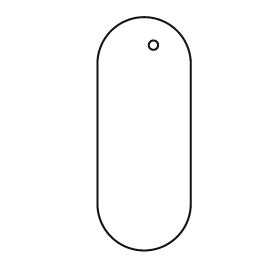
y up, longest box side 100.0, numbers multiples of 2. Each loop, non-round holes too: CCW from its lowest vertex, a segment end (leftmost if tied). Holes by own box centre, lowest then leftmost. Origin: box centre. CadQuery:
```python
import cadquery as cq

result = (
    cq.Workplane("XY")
    .moveTo(-20.0, -30.0)
    .threePointArc((0.0, -50.0), (20.0, -30.0))
    .lineTo(20.0, 30.0)
    .threePointArc((0.0, 50.0), (-20.0, 30.0))
    .close()
    .moveTo(4.0, 38.0)
    .circle(2.0)
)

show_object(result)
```